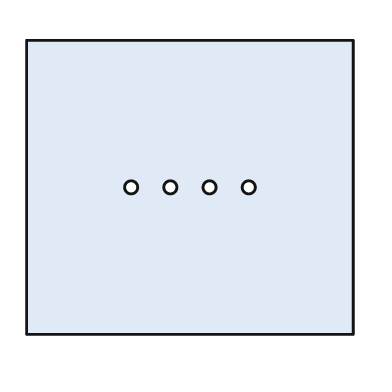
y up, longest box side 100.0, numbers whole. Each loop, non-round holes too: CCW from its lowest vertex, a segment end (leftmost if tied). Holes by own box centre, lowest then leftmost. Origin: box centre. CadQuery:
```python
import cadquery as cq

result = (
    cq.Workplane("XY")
    .moveTo(-50.0, -45.0)
    .lineTo(50.0, -45.0)
    .lineTo(50.0, 45.0)
    .lineTo(-50.0, 45.0)
    .close()
    .moveTo(-18.0, 0.0)
    .circle(2.0)
    .moveTo(-6.0, 0.0)
    .circle(2.0)
    .moveTo(6.0, 0.0)
    .circle(2.0)
    .moveTo(18.0, 0.0)
    .circle(2.0)
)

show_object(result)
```